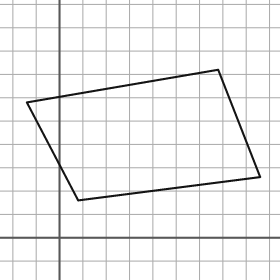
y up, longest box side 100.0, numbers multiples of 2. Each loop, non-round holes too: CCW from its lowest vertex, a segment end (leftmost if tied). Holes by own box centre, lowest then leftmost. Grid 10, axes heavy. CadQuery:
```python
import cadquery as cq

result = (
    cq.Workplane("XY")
    .moveTo(8.0, 16.0)
    .lineTo(86.0, 26.0)
    .lineTo(68.0, 72.0)
    .lineTo(-14.0, 58.0)
    .close()
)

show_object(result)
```